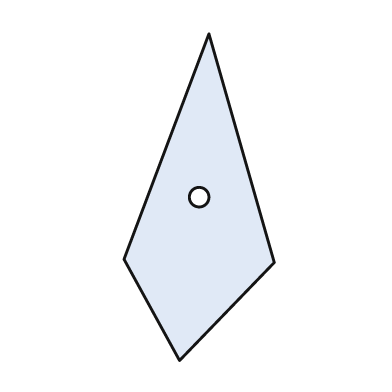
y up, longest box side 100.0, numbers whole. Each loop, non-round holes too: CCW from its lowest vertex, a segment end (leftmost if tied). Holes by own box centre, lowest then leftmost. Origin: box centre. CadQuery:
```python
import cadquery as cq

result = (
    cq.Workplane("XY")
    .moveTo(-6.0, -50.0)
    .lineTo(23.0, -20.0)
    .lineTo(3.0, 50.0)
    .lineTo(-23.0, -19.0)
    .close()
    .moveTo(0.0, 0.0)
    .circle(3.0)
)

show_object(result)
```